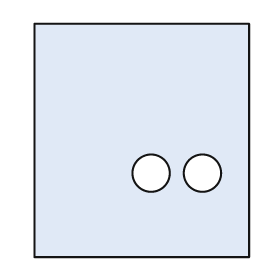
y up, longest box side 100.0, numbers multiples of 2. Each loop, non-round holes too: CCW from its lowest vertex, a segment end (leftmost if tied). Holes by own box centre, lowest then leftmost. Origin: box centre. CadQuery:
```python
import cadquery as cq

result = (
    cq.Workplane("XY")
    .moveTo(-46.0, -50.0)
    .lineTo(46.0, -50.0)
    .lineTo(46.0, 50.0)
    .lineTo(-46.0, 50.0)
    .close()
    .moveTo(4.0, -14.0)
    .circle(8.0)
    .moveTo(26.0, -14.0)
    .circle(8.0)
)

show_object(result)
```